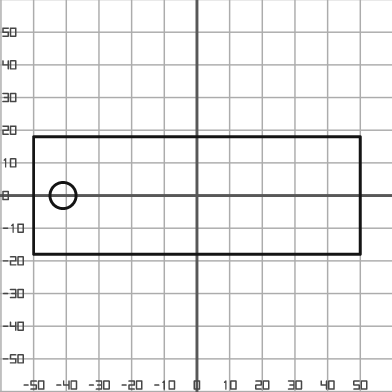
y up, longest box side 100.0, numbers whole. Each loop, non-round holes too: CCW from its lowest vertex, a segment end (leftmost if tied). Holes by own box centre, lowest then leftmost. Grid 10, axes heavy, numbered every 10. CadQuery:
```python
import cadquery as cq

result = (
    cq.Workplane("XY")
    .moveTo(-50.0, -18.0)
    .lineTo(50.0, -18.0)
    .lineTo(50.0, 18.0)
    .lineTo(-50.0, 18.0)
    .close()
    .moveTo(-41.0, 0.0)
    .circle(4.0)
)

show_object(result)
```